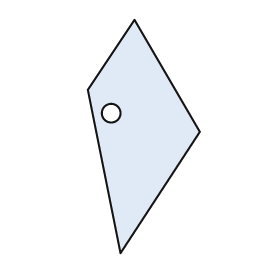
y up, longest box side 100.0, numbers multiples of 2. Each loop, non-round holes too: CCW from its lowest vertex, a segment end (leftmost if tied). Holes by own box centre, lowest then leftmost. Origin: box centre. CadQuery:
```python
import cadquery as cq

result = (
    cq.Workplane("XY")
    .moveTo(-10.0, -50.0)
    .lineTo(24.0, 2.0)
    .lineTo(-4.0, 50.0)
    .lineTo(-24.0, 20.0)
    .close()
    .moveTo(-14.0, 10.0)
    .circle(4.0)
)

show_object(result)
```